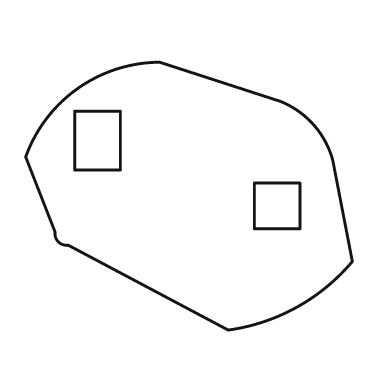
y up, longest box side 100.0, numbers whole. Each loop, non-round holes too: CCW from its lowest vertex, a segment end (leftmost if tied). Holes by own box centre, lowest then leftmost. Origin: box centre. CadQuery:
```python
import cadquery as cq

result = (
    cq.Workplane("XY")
    .moveTo(12.0, -41.0)
    .threePointArc((33.0, -34.0), (50.0, -20.0))
    .lineTo(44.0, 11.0)
    .threePointArc((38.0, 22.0), (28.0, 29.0))
    .lineTo(-9.0, 41.0)
    .threePointArc((-34.0, 33.0), (-50.0, 12.0))
    .lineTo(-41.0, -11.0)
    .threePointArc((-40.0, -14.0), (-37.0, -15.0))
    .close()
    .moveTo(20.0, -10.0)
    .lineTo(34.0, -10.0)
    .lineTo(34.0, 4.0)
    .lineTo(20.0, 4.0)
    .close()
    .moveTo(-35.0, 8.0)
    .lineTo(-21.0, 8.0)
    .lineTo(-21.0, 26.0)
    .lineTo(-35.0, 26.0)
    .close()
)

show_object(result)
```